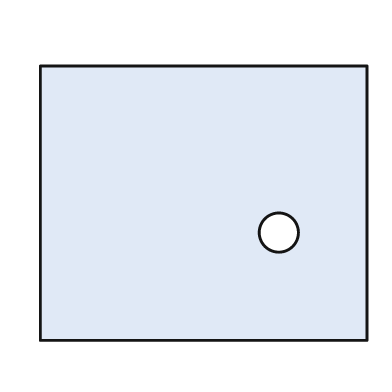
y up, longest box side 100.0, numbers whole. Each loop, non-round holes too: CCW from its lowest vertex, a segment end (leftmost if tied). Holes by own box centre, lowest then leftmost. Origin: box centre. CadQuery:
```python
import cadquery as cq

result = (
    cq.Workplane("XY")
    .moveTo(-50.0, -42.0)
    .lineTo(50.0, -42.0)
    .lineTo(50.0, 42.0)
    .lineTo(-50.0, 42.0)
    .close()
    .moveTo(23.0, -9.0)
    .circle(6.0)
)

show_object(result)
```